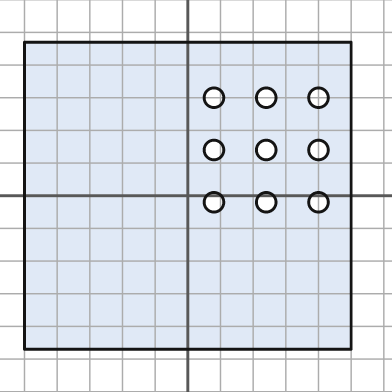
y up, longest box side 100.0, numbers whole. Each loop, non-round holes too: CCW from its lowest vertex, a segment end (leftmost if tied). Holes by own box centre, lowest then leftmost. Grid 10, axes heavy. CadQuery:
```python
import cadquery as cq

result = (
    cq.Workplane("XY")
    .moveTo(-50.0, -47.0)
    .lineTo(50.0, -47.0)
    .lineTo(50.0, 47.0)
    .lineTo(-50.0, 47.0)
    .close()
    .moveTo(8.0, -2.0)
    .circle(3.0)
    .moveTo(24.0, -2.0)
    .circle(3.0)
    .moveTo(40.0, -2.0)
    .circle(3.0)
    .moveTo(8.0, 14.0)
    .circle(3.0)
    .moveTo(24.0, 14.0)
    .circle(3.0)
    .moveTo(40.0, 14.0)
    .circle(3.0)
    .moveTo(8.0, 30.0)
    .circle(3.0)
    .moveTo(24.0, 30.0)
    .circle(3.0)
    .moveTo(40.0, 30.0)
    .circle(3.0)
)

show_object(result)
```